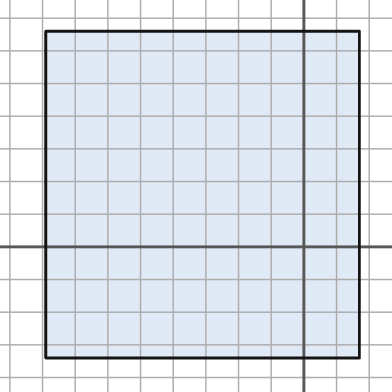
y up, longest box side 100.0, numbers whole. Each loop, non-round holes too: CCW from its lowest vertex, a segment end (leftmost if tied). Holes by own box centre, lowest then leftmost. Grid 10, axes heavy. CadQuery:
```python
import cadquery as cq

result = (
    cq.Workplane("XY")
    .moveTo(-79.0, -34.0)
    .lineTo(17.0, -34.0)
    .lineTo(17.0, 66.0)
    .lineTo(-79.0, 66.0)
    .close()
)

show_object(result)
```